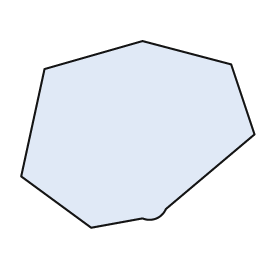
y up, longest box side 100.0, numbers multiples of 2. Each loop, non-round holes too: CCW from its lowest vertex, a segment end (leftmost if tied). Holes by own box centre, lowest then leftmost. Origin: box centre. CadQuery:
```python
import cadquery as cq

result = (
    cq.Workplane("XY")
    .moveTo(-20.0, -40.0)
    .lineTo(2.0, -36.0)
    .threePointArc((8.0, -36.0), (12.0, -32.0))
    .lineTo(50.0, 0.0)
    .lineTo(40.0, 30.0)
    .lineTo(2.0, 40.0)
    .lineTo(-40.0, 28.0)
    .lineTo(-50.0, -18.0)
    .close()
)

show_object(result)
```